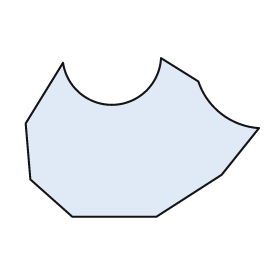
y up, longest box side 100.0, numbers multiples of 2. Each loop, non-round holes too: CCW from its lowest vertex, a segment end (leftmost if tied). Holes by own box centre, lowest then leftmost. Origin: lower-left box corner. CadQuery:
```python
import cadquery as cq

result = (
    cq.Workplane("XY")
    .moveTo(20.0, 0.0)
    .lineTo(56.0, 0.0)
    .lineTo(84.0, 18.0)
    .lineTo(100.0, 38.0)
    .threePointArc((84.0, 44.0), (74.0, 58.0))
    .lineTo(58.0, 68.0)
    .threePointArc((38.0, 48.0), (16.0, 66.0))
    .lineTo(0.0, 40.0)
    .lineTo(2.0, 16.0)
    .close()
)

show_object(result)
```